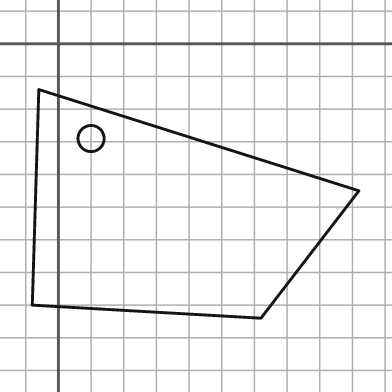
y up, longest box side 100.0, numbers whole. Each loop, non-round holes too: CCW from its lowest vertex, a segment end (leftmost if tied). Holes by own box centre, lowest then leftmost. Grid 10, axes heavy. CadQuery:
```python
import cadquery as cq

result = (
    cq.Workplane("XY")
    .moveTo(62.0, -84.0)
    .lineTo(92.0, -45.0)
    .lineTo(-6.0, -14.0)
    .lineTo(-8.0, -80.0)
    .close()
    .moveTo(10.0, -29.0)
    .circle(4.0)
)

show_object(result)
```